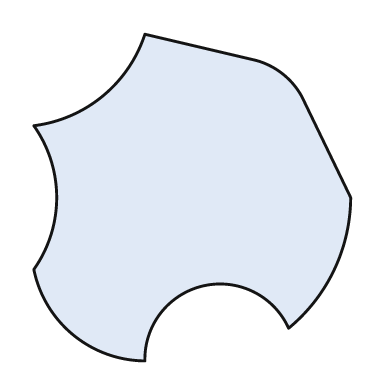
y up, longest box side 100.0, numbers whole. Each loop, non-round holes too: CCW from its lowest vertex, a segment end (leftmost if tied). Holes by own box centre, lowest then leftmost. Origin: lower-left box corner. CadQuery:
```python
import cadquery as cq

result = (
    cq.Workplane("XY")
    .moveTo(34.0, 0.0)
    .threePointArc((52.0, 23.0), (78.0, 10.0))
    .threePointArc((92.0, 28.0), (97.0, 50.0))
    .lineTo(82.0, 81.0)
    .threePointArc((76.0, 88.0), (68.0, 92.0))
    .lineTo(34.0, 100.0)
    .threePointArc((21.0, 81.0), (0.0, 72.0))
    .threePointArc((7.0, 50.0), (0.0, 28.0))
    .threePointArc((12.0, 8.0), (34.0, 0.0))
    .close()
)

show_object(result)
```